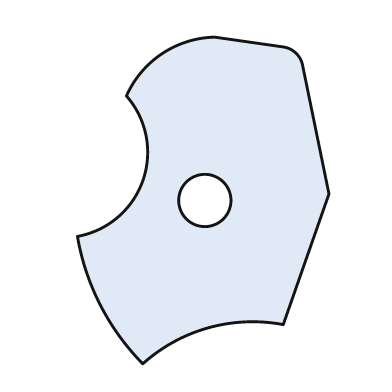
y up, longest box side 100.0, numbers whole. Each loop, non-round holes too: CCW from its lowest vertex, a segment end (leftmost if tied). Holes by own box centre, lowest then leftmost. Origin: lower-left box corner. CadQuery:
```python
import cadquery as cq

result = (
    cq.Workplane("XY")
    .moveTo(20.0, 0.0)
    .threePointArc((40.0, 11.0), (63.0, 12.0))
    .lineTo(77.0, 52.0)
    .lineTo(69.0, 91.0)
    .threePointArc((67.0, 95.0), (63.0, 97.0))
    .lineTo(42.0, 100.0)
    .threePointArc((26.0, 95.0), (15.0, 82.0))
    .threePointArc((20.0, 56.0), (0.0, 39.0))
    .threePointArc((7.0, 18.0), (20.0, 0.0))
    .close()
    .moveTo(39.0, 50.0)
    .circle(8.0)
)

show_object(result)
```